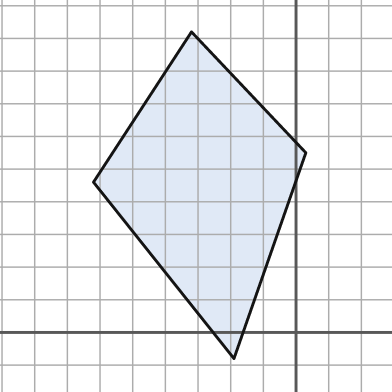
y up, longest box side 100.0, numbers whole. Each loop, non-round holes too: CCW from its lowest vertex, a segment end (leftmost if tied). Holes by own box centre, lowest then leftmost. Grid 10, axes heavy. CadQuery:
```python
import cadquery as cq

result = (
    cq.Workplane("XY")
    .moveTo(-19.0, -8.0)
    .lineTo(3.0, 55.0)
    .lineTo(-32.0, 92.0)
    .lineTo(-62.0, 46.0)
    .close()
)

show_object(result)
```